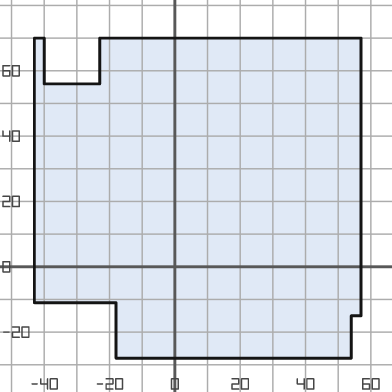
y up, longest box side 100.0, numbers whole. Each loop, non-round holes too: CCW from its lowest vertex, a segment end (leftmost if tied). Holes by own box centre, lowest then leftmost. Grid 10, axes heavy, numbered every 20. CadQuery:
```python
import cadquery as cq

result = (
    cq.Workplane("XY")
    .moveTo(-18.0, -28.0)
    .lineTo(54.0, -28.0)
    .lineTo(54.0, -15.0)
    .lineTo(57.0, -15.0)
    .lineTo(57.0, 70.0)
    .lineTo(-23.0, 70.0)
    .lineTo(-23.0, 56.0)
    .lineTo(-40.0, 56.0)
    .lineTo(-40.0, 70.0)
    .lineTo(-43.0, 70.0)
    .lineTo(-43.0, -11.0)
    .lineTo(-18.0, -11.0)
    .close()
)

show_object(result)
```